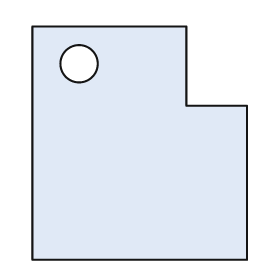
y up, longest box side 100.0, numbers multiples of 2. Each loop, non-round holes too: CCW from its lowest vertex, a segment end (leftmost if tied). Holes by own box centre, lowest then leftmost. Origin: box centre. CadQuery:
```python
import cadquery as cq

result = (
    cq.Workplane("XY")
    .moveTo(-46.0, -50.0)
    .lineTo(46.0, -50.0)
    .lineTo(46.0, 16.0)
    .lineTo(20.0, 16.0)
    .lineTo(20.0, 50.0)
    .lineTo(-46.0, 50.0)
    .close()
    .moveTo(-26.0, 34.0)
    .circle(8.0)
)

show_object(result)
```